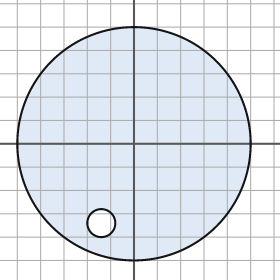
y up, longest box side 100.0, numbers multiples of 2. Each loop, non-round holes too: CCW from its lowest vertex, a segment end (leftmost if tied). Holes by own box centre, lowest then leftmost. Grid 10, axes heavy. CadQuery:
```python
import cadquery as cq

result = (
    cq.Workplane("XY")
    .moveTo(0.0, 0.0)
    .circle(50.0)
    .moveTo(-14.0, -34.0)
    .circle(6.0)
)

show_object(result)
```